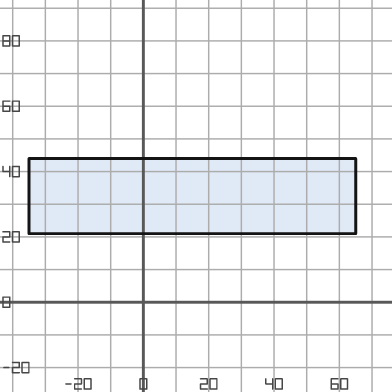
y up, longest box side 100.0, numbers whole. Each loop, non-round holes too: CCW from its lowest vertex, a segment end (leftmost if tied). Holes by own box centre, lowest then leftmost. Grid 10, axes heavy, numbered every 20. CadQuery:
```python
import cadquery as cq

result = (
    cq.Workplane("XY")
    .moveTo(-35.0, 21.0)
    .lineTo(65.0, 21.0)
    .lineTo(65.0, 44.0)
    .lineTo(-35.0, 44.0)
    .close()
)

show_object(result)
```